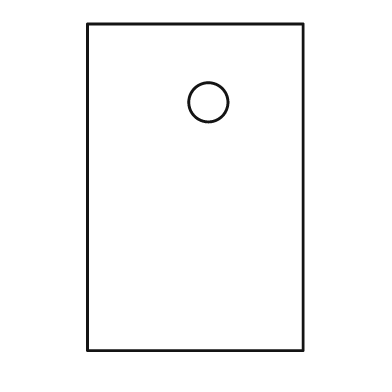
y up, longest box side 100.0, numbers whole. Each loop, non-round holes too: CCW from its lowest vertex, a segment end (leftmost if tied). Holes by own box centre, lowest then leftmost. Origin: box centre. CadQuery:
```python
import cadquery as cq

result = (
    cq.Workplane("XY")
    .moveTo(-33.0, -50.0)
    .lineTo(33.0, -50.0)
    .lineTo(33.0, 50.0)
    .lineTo(-33.0, 50.0)
    .close()
    .moveTo(4.0, 26.0)
    .circle(6.0)
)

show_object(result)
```